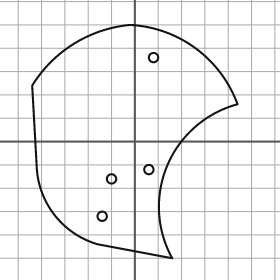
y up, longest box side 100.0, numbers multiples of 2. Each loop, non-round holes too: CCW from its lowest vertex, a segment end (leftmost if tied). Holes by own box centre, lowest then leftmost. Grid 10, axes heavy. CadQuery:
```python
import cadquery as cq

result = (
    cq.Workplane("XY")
    .moveTo(16.0, -50.0)
    .threePointArc((14.0, -10.0), (44.0, 16.0))
    .threePointArc((26.0, 40.0), (-2.0, 50.0))
    .threePointArc((-26.0, 42.0), (-44.0, 24.0))
    .lineTo(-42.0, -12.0)
    .threePointArc((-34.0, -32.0), (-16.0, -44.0))
    .close()
    .moveTo(-14.0, -32.0)
    .circle(2.0)
    .moveTo(-10.0, -16.0)
    .circle(2.0)
    .moveTo(6.0, -12.0)
    .circle(2.0)
    .moveTo(8.0, 36.0)
    .circle(2.0)
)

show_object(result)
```